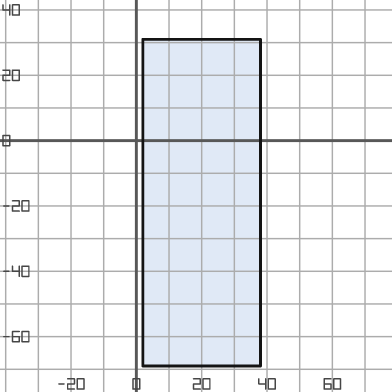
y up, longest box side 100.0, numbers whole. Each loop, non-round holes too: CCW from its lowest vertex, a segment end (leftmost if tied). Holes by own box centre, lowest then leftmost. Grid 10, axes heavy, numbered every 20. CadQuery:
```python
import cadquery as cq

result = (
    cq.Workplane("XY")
    .moveTo(2.0, -69.0)
    .lineTo(38.0, -69.0)
    .lineTo(38.0, 31.0)
    .lineTo(2.0, 31.0)
    .close()
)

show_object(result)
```